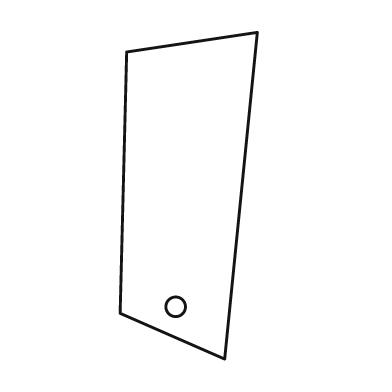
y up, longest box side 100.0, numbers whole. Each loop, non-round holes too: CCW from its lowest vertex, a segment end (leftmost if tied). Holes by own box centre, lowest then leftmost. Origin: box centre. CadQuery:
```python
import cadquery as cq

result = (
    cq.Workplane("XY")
    .moveTo(11.0, -50.0)
    .lineTo(21.0, 50.0)
    .lineTo(-19.0, 44.0)
    .lineTo(-21.0, -36.0)
    .close()
    .moveTo(-4.0, -34.0)
    .circle(3.0)
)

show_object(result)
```